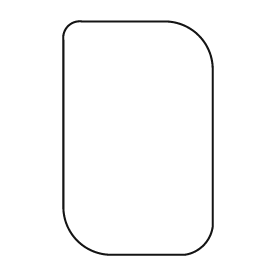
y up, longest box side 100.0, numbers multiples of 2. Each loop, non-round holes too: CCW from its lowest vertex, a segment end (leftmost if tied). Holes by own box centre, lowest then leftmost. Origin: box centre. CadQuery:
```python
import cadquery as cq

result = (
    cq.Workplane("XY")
    .moveTo(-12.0, -50.0)
    .lineTo(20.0, -50.0)
    .threePointArc((28.0, -46.0), (32.0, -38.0))
    .lineTo(32.0, 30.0)
    .threePointArc((26.0, 44.0), (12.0, 50.0))
    .lineTo(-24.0, 50.0)
    .threePointArc((-30.0, 48.0), (-32.0, 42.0))
    .lineTo(-32.0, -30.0)
    .threePointArc((-26.0, -44.0), (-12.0, -50.0))
    .close()
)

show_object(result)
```